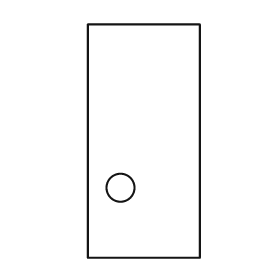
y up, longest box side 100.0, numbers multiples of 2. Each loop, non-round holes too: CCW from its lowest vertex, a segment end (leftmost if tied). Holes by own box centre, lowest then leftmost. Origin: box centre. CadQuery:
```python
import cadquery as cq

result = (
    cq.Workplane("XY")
    .moveTo(-24.0, -50.0)
    .lineTo(24.0, -50.0)
    .lineTo(24.0, 50.0)
    .lineTo(-24.0, 50.0)
    .close()
    .moveTo(-10.0, -20.0)
    .circle(6.0)
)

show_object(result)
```